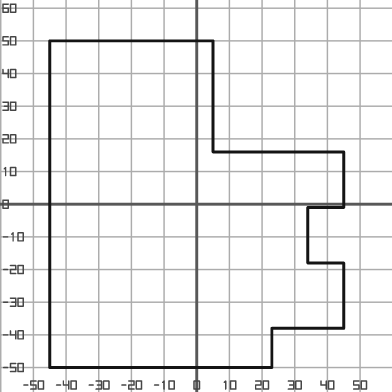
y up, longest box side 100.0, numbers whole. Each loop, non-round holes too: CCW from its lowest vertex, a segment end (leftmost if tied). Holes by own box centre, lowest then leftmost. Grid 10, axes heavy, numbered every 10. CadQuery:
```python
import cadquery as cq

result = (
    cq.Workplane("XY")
    .moveTo(-45.0, -50.0)
    .lineTo(23.0, -50.0)
    .lineTo(23.0, -38.0)
    .lineTo(45.0, -38.0)
    .lineTo(45.0, -18.0)
    .lineTo(34.0, -18.0)
    .lineTo(34.0, -1.0)
    .lineTo(45.0, -1.0)
    .lineTo(45.0, 16.0)
    .lineTo(5.0, 16.0)
    .lineTo(5.0, 50.0)
    .lineTo(-45.0, 50.0)
    .close()
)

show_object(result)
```